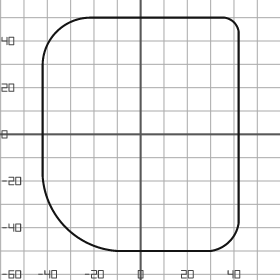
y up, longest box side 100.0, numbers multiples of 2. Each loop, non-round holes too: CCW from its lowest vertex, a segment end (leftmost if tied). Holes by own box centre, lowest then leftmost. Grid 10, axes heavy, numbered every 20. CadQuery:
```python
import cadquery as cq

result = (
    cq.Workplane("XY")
    .moveTo(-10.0, -50.0)
    .lineTo(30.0, -50.0)
    .threePointArc((38.0, -46.0), (42.0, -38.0))
    .lineTo(42.0, 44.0)
    .threePointArc((40.0, 48.0), (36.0, 50.0))
    .lineTo(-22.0, 50.0)
    .threePointArc((-36.0, 44.0), (-42.0, 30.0))
    .lineTo(-42.0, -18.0)
    .threePointArc((-32.0, -40.0), (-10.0, -50.0))
    .close()
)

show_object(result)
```